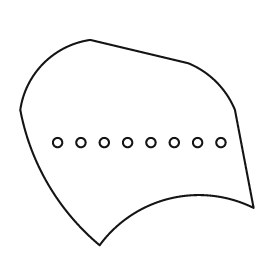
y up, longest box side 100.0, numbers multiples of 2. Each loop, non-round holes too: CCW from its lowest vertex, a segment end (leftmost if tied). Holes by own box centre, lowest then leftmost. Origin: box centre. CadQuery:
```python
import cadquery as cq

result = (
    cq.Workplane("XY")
    .moveTo(-16.0, -44.0)
    .threePointArc((14.0, -24.0), (50.0, -28.0))
    .lineTo(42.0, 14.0)
    .threePointArc((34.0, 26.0), (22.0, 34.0))
    .lineTo(-20.0, 44.0)
    .threePointArc((-40.0, 34.0), (-50.0, 14.0))
    .threePointArc((-38.0, -18.0), (-16.0, -44.0))
    .close()
    .moveTo(-34.0, 0.0)
    .circle(2.0)
    .moveTo(-24.0, 0.0)
    .circle(2.0)
    .moveTo(-14.0, 0.0)
    .circle(2.0)
    .moveTo(-4.0, 0.0)
    .circle(2.0)
    .moveTo(6.0, 0.0)
    .circle(2.0)
    .moveTo(16.0, 0.0)
    .circle(2.0)
    .moveTo(26.0, 0.0)
    .circle(2.0)
    .moveTo(36.0, 0.0)
    .circle(2.0)
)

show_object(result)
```